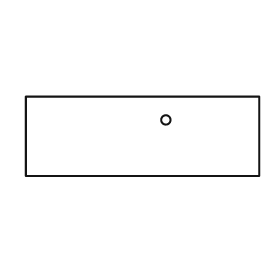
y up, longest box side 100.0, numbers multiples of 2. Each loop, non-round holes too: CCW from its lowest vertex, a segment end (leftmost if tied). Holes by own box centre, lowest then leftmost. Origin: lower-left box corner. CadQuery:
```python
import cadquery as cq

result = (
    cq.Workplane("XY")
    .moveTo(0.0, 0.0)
    .lineTo(100.0, 0.0)
    .lineTo(100.0, 34.0)
    .lineTo(0.0, 34.0)
    .close()
    .moveTo(60.0, 24.0)
    .circle(2.0)
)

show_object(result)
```